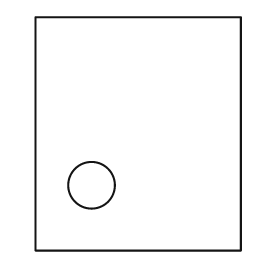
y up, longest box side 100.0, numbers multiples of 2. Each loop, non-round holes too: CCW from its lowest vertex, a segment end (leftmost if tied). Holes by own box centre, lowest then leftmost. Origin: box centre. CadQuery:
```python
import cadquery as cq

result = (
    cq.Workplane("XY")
    .moveTo(-44.0, -50.0)
    .lineTo(44.0, -50.0)
    .lineTo(44.0, 50.0)
    .lineTo(-44.0, 50.0)
    .close()
    .moveTo(-20.0, -22.0)
    .circle(10.0)
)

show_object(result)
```